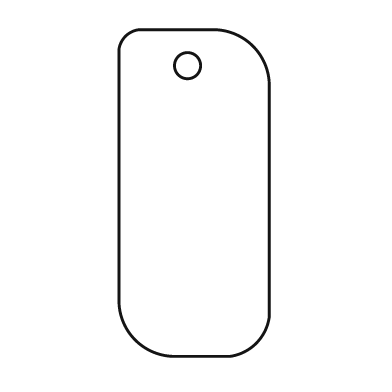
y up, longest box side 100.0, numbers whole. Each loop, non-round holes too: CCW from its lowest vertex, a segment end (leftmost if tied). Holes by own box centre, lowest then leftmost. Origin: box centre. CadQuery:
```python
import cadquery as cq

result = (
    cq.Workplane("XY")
    .moveTo(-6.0, -50.0)
    .lineTo(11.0, -50.0)
    .threePointArc((19.0, -46.0), (23.0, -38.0))
    .lineTo(23.0, 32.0)
    .threePointArc((18.0, 45.0), (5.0, 50.0))
    .lineTo(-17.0, 50.0)
    .threePointArc((-21.0, 48.0), (-23.0, 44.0))
    .lineTo(-23.0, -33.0)
    .threePointArc((-18.0, -45.0), (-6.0, -50.0))
    .close()
    .moveTo(-2.0, 39.0)
    .circle(4.0)
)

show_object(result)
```